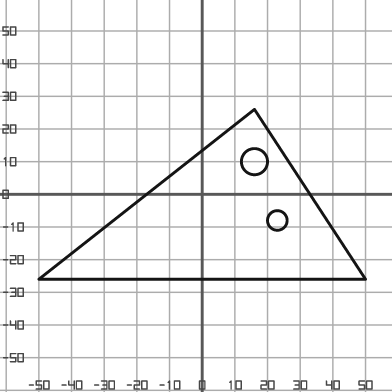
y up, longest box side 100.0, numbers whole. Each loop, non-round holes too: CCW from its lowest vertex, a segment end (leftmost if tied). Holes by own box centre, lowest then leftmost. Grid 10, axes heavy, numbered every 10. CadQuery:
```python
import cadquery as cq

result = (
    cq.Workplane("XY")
    .moveTo(-50.0, -26.0)
    .lineTo(50.0, -26.0)
    .lineTo(16.0, 26.0)
    .close()
    .moveTo(23.0, -8.0)
    .circle(3.0)
    .moveTo(16.0, 10.0)
    .circle(4.0)
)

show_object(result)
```